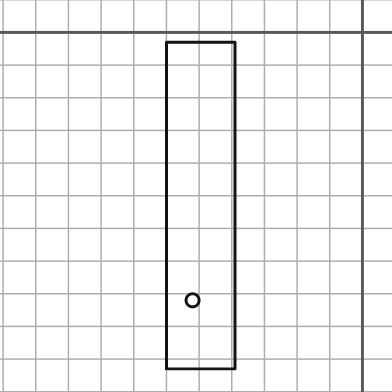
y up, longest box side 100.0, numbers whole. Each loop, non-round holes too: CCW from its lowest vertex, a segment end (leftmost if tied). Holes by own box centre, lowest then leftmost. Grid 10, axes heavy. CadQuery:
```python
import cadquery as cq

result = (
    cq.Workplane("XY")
    .moveTo(-60.0, -103.0)
    .lineTo(-39.0, -103.0)
    .lineTo(-39.0, -3.0)
    .lineTo(-60.0, -3.0)
    .close()
    .moveTo(-52.0, -82.0)
    .circle(2.0)
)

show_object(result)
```